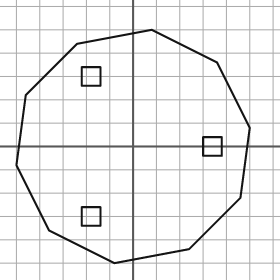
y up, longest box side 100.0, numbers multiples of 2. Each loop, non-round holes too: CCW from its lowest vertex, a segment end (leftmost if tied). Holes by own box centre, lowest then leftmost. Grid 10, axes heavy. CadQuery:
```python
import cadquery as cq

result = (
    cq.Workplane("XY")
    .moveTo(-8.0, -50.0)
    .lineTo(24.0, -44.0)
    .lineTo(46.0, -22.0)
    .lineTo(50.0, 8.0)
    .lineTo(36.0, 36.0)
    .lineTo(8.0, 50.0)
    .lineTo(-24.0, 44.0)
    .lineTo(-46.0, 22.0)
    .lineTo(-50.0, -8.0)
    .lineTo(-36.0, -36.0)
    .close()
    .moveTo(-22.0, -34.0)
    .lineTo(-14.0, -34.0)
    .lineTo(-14.0, -26.0)
    .lineTo(-22.0, -26.0)
    .close()
    .moveTo(30.0, -4.0)
    .lineTo(38.0, -4.0)
    .lineTo(38.0, 4.0)
    .lineTo(30.0, 4.0)
    .close()
    .moveTo(-22.0, 26.0)
    .lineTo(-14.0, 26.0)
    .lineTo(-14.0, 34.0)
    .lineTo(-22.0, 34.0)
    .close()
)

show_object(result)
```